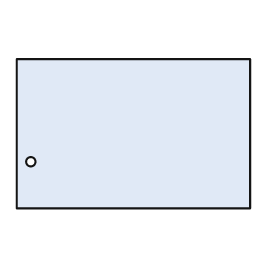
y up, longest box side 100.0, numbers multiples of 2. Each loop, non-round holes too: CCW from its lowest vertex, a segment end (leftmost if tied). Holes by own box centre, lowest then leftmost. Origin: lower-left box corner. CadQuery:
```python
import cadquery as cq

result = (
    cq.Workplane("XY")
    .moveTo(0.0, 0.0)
    .lineTo(100.0, 0.0)
    .lineTo(100.0, 64.0)
    .lineTo(0.0, 64.0)
    .close()
    .moveTo(6.0, 20.0)
    .circle(2.0)
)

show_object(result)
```